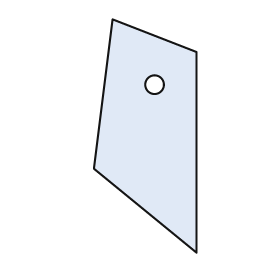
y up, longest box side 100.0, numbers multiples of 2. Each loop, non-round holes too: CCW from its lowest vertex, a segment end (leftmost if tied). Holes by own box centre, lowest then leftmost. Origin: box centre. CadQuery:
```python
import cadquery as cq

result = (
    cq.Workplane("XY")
    .moveTo(22.0, -50.0)
    .lineTo(22.0, 36.0)
    .lineTo(-14.0, 50.0)
    .lineTo(-22.0, -14.0)
    .close()
    .moveTo(4.0, 22.0)
    .circle(4.0)
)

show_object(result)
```